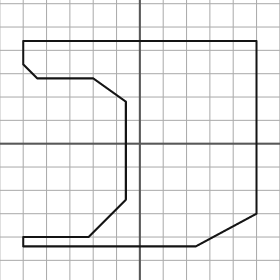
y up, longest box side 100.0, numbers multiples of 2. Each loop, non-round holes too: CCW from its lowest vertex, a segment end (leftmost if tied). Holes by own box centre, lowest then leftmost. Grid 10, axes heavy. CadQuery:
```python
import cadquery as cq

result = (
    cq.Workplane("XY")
    .moveTo(-50.0, -44.0)
    .lineTo(24.0, -44.0)
    .lineTo(50.0, -30.0)
    .lineTo(50.0, 44.0)
    .lineTo(-50.0, 44.0)
    .lineTo(-50.0, 34.0)
    .lineTo(-44.0, 28.0)
    .lineTo(-20.0, 28.0)
    .lineTo(-6.0, 18.0)
    .lineTo(-6.0, -24.0)
    .lineTo(-22.0, -40.0)
    .lineTo(-50.0, -40.0)
    .close()
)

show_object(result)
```